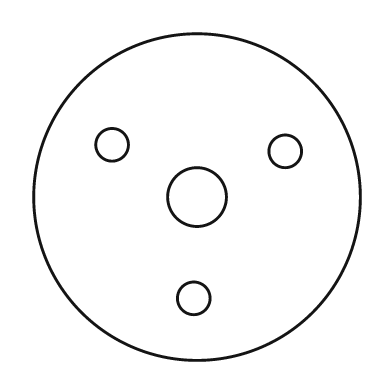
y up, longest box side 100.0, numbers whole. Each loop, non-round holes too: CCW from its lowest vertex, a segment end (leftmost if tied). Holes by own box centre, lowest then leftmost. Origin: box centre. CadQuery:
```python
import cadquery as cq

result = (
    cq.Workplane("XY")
    .moveTo(0.0, 0.0)
    .circle(50.0)
    .moveTo(-1.0, -31.0)
    .circle(5.0)
    .moveTo(0.0, 0.0)
    .circle(9.0)
    .moveTo(27.0, 14.0)
    .circle(5.0)
    .moveTo(-26.0, 16.0)
    .circle(5.0)
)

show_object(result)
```